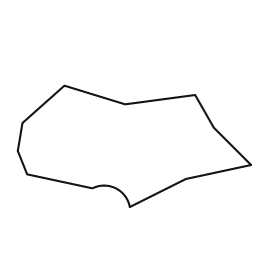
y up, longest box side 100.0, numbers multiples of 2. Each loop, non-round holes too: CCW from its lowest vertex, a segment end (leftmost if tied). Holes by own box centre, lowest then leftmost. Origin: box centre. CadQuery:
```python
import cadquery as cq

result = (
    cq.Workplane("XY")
    .moveTo(-2.0, -26.0)
    .lineTo(22.0, -14.0)
    .lineTo(50.0, -8.0)
    .lineTo(34.0, 8.0)
    .lineTo(26.0, 22.0)
    .lineTo(-4.0, 18.0)
    .lineTo(-30.0, 26.0)
    .lineTo(-48.0, 10.0)
    .lineTo(-50.0, -2.0)
    .lineTo(-46.0, -12.0)
    .lineTo(-18.0, -18.0)
    .threePointArc((-8.0, -18.0), (-2.0, -26.0))
    .close()
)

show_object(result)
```